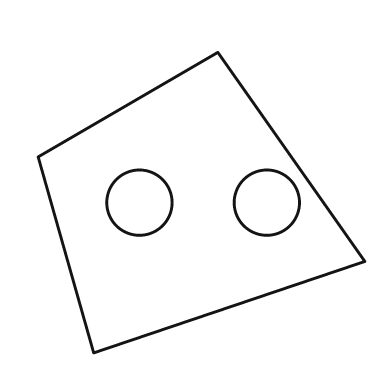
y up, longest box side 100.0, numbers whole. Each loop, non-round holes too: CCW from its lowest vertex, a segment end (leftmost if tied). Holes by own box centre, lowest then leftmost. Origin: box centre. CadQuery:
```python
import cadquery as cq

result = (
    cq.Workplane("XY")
    .moveTo(-33.0, -46.0)
    .lineTo(50.0, -18.0)
    .lineTo(5.0, 46.0)
    .lineTo(-50.0, 14.0)
    .close()
    .moveTo(-19.0, 0.0)
    .circle(10.0)
    .moveTo(20.0, 0.0)
    .circle(10.0)
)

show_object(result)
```